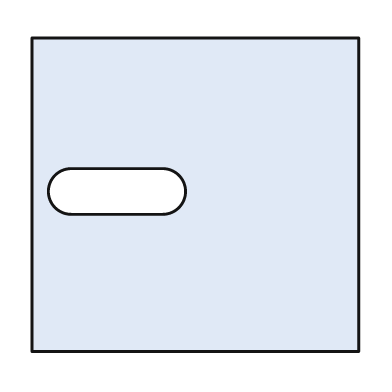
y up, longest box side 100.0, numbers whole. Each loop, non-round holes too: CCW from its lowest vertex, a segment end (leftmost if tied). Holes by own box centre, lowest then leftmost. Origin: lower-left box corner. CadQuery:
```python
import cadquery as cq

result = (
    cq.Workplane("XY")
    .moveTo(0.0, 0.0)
    .lineTo(100.0, 0.0)
    .lineTo(100.0, 96.0)
    .lineTo(0.0, 96.0)
    .close()
    .moveTo(12.0, 42.0)
    .lineTo(40.0, 42.0)
    .threePointArc((47.0, 49.0), (40.0, 56.0))
    .lineTo(12.0, 56.0)
    .threePointArc((5.0, 49.0), (12.0, 42.0))
    .close()
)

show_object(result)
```